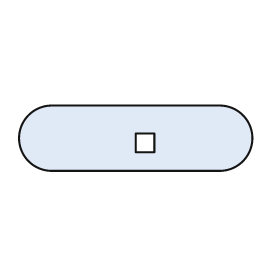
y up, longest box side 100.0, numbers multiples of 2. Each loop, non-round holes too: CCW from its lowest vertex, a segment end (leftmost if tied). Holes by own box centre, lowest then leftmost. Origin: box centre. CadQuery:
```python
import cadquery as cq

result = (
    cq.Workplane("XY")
    .moveTo(-36.0, -14.0)
    .lineTo(36.0, -14.0)
    .threePointArc((50.0, 0.0), (36.0, 14.0))
    .lineTo(-36.0, 14.0)
    .threePointArc((-50.0, 0.0), (-36.0, -14.0))
    .close()
    .moveTo(0.0, -6.0)
    .lineTo(8.0, -6.0)
    .lineTo(8.0, 2.0)
    .lineTo(0.0, 2.0)
    .close()
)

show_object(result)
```